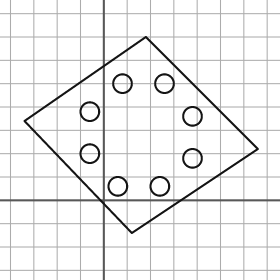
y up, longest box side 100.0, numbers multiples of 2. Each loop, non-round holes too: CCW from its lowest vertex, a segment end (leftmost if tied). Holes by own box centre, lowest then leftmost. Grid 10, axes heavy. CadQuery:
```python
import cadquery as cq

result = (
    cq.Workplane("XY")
    .moveTo(12.0, -14.0)
    .lineTo(66.0, 22.0)
    .lineTo(18.0, 70.0)
    .lineTo(-34.0, 34.0)
    .close()
    .moveTo(6.0, 6.0)
    .circle(4.0)
    .moveTo(24.0, 6.0)
    .circle(4.0)
    .moveTo(38.0, 18.0)
    .circle(4.0)
    .moveTo(-6.0, 20.0)
    .circle(4.0)
    .moveTo(38.0, 36.0)
    .circle(4.0)
    .moveTo(-6.0, 38.0)
    .circle(4.0)
    .moveTo(8.0, 50.0)
    .circle(4.0)
    .moveTo(26.0, 50.0)
    .circle(4.0)
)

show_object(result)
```